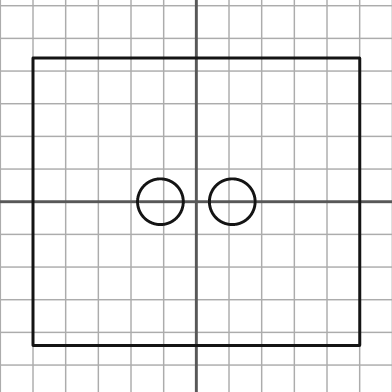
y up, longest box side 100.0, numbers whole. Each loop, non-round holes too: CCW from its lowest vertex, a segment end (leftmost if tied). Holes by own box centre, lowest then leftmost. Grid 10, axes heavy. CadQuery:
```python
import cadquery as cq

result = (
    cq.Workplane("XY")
    .moveTo(-50.0, -44.0)
    .lineTo(50.0, -44.0)
    .lineTo(50.0, 44.0)
    .lineTo(-50.0, 44.0)
    .close()
    .moveTo(-11.0, 0.0)
    .circle(7.0)
    .moveTo(11.0, 0.0)
    .circle(7.0)
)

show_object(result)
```